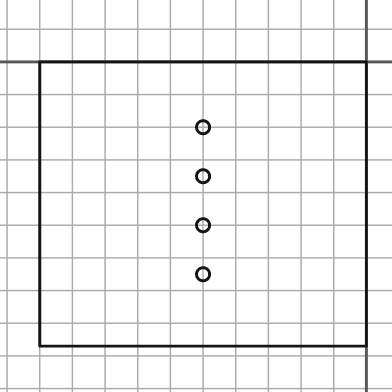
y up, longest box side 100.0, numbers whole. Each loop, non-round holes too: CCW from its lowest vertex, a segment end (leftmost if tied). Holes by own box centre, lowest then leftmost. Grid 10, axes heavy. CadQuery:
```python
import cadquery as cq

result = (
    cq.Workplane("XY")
    .moveTo(-100.0, -87.0)
    .lineTo(0.0, -87.0)
    .lineTo(0.0, 0.0)
    .lineTo(-100.0, 0.0)
    .close()
    .moveTo(-50.0, -65.0)
    .circle(2.0)
    .moveTo(-50.0, -50.0)
    .circle(2.0)
    .moveTo(-50.0, -35.0)
    .circle(2.0)
    .moveTo(-50.0, -20.0)
    .circle(2.0)
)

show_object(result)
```